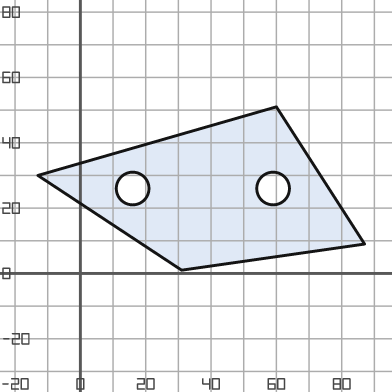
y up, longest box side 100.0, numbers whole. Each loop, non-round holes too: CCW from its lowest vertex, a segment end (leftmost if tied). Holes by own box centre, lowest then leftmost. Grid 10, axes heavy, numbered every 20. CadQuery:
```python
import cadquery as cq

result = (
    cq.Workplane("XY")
    .moveTo(31.0, 1.0)
    .lineTo(87.0, 9.0)
    .lineTo(60.0, 51.0)
    .lineTo(-13.0, 30.0)
    .close()
    .moveTo(16.0, 26.0)
    .circle(5.0)
    .moveTo(59.0, 26.0)
    .circle(5.0)
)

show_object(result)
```